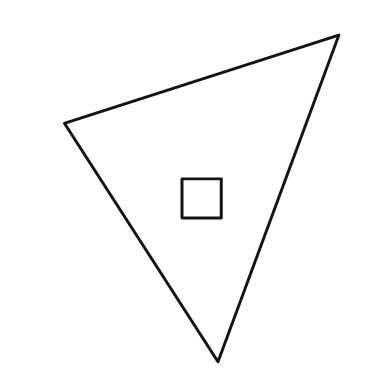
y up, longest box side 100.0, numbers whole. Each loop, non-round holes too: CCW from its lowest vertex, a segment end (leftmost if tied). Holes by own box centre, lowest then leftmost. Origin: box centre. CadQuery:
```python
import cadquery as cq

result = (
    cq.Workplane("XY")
    .moveTo(5.0, -50.0)
    .lineTo(42.0, 50.0)
    .lineTo(-42.0, 23.0)
    .close()
    .moveTo(-6.0, -6.0)
    .lineTo(6.0, -6.0)
    .lineTo(6.0, 6.0)
    .lineTo(-6.0, 6.0)
    .close()
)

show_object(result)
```